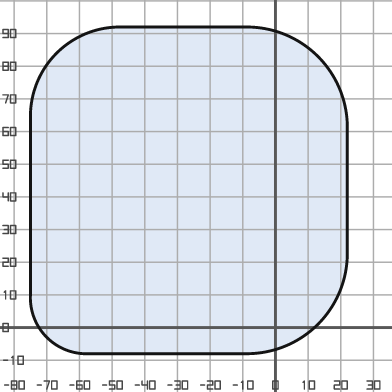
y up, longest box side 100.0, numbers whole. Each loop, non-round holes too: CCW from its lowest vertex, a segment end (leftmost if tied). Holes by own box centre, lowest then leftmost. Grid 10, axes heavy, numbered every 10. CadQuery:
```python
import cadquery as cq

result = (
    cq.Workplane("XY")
    .moveTo(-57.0, -8.0)
    .lineTo(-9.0, -8.0)
    .threePointArc((13.0, 1.0), (22.0, 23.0))
    .lineTo(22.0, 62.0)
    .threePointArc((13.0, 83.0), (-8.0, 92.0))
    .lineTo(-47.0, 92.0)
    .threePointArc((-67.0, 84.0), (-75.0, 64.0))
    .lineTo(-75.0, 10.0)
    .threePointArc((-70.0, -3.0), (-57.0, -8.0))
    .close()
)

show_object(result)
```